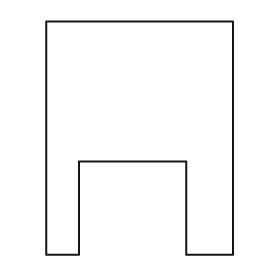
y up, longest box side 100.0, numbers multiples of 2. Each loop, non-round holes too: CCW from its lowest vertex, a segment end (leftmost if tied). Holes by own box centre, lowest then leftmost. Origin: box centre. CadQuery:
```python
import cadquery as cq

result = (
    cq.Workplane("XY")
    .moveTo(-40.0, -50.0)
    .lineTo(-26.0, -50.0)
    .lineTo(-26.0, -10.0)
    .lineTo(20.0, -10.0)
    .lineTo(20.0, -50.0)
    .lineTo(40.0, -50.0)
    .lineTo(40.0, 50.0)
    .lineTo(-40.0, 50.0)
    .close()
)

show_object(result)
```